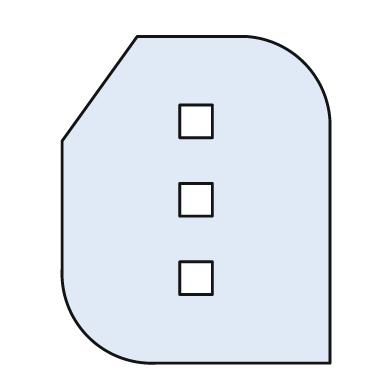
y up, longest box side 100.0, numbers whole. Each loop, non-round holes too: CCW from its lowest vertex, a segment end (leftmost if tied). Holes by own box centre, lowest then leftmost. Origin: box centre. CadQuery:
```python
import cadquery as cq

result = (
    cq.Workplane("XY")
    .moveTo(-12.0, -50.0)
    .lineTo(41.0, -50.0)
    .lineTo(41.0, 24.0)
    .threePointArc((33.0, 42.0), (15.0, 50.0))
    .lineTo(-18.0, 50.0)
    .lineTo(-41.0, 18.0)
    .lineTo(-41.0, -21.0)
    .threePointArc((-33.0, -42.0), (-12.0, -50.0))
    .close()
    .moveTo(-5.0, -29.0)
    .lineTo(5.0, -29.0)
    .lineTo(5.0, -19.0)
    .lineTo(-5.0, -19.0)
    .close()
    .moveTo(-5.0, -5.0)
    .lineTo(5.0, -5.0)
    .lineTo(5.0, 5.0)
    .lineTo(-5.0, 5.0)
    .close()
    .moveTo(-5.0, 19.0)
    .lineTo(5.0, 19.0)
    .lineTo(5.0, 29.0)
    .lineTo(-5.0, 29.0)
    .close()
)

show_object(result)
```